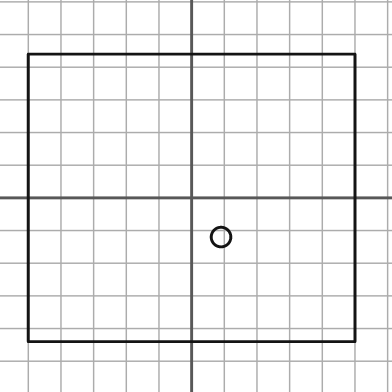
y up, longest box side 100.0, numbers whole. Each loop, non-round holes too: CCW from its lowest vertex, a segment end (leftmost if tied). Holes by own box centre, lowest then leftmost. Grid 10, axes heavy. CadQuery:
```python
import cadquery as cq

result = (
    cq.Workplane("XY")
    .moveTo(-50.0, -44.0)
    .lineTo(50.0, -44.0)
    .lineTo(50.0, 44.0)
    .lineTo(-50.0, 44.0)
    .close()
    .moveTo(9.0, -12.0)
    .circle(3.0)
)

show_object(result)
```